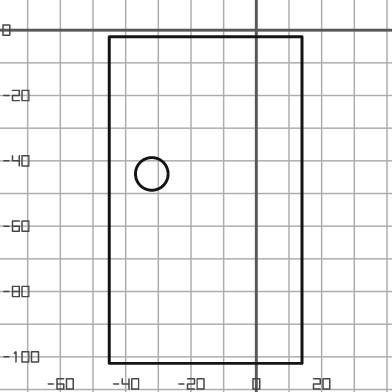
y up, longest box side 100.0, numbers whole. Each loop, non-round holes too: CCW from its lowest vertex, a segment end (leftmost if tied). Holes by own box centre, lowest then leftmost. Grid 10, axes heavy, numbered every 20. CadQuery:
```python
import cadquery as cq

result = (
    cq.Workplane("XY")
    .moveTo(-45.0, -102.0)
    .lineTo(14.0, -102.0)
    .lineTo(14.0, -2.0)
    .lineTo(-45.0, -2.0)
    .close()
    .moveTo(-32.0, -44.0)
    .circle(5.0)
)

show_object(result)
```